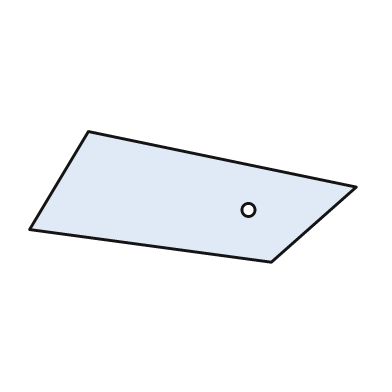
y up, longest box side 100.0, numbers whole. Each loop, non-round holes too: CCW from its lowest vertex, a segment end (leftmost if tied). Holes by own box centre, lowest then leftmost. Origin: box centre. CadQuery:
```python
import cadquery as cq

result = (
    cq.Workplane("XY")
    .moveTo(24.0, -20.0)
    .lineTo(50.0, 3.0)
    .lineTo(-32.0, 20.0)
    .lineTo(-50.0, -10.0)
    .close()
    .moveTo(17.0, -4.0)
    .circle(2.0)
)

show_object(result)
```